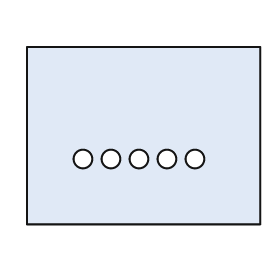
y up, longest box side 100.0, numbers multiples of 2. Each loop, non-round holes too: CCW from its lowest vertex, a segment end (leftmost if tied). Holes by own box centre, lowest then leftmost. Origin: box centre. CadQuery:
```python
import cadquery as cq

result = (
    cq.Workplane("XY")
    .moveTo(-50.0, -38.0)
    .lineTo(50.0, -38.0)
    .lineTo(50.0, 38.0)
    .lineTo(-50.0, 38.0)
    .close()
    .moveTo(-26.0, -10.0)
    .circle(4.0)
    .moveTo(-14.0, -10.0)
    .circle(4.0)
    .moveTo(-2.0, -10.0)
    .circle(4.0)
    .moveTo(10.0, -10.0)
    .circle(4.0)
    .moveTo(22.0, -10.0)
    .circle(4.0)
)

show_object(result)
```